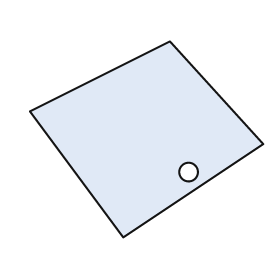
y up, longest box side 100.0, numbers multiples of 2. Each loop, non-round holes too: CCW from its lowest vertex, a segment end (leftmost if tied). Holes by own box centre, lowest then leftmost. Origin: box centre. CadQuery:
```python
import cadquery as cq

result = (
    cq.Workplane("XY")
    .moveTo(-10.0, -42.0)
    .lineTo(50.0, -2.0)
    .lineTo(10.0, 42.0)
    .lineTo(-50.0, 12.0)
    .close()
    .moveTo(18.0, -14.0)
    .circle(4.0)
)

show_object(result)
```